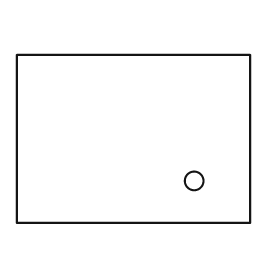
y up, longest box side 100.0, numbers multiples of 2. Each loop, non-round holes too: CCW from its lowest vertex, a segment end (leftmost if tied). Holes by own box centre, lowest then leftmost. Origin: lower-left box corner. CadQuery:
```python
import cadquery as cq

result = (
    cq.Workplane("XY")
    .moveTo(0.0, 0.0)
    .lineTo(100.0, 0.0)
    .lineTo(100.0, 72.0)
    .lineTo(0.0, 72.0)
    .close()
    .moveTo(76.0, 18.0)
    .circle(4.0)
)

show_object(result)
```